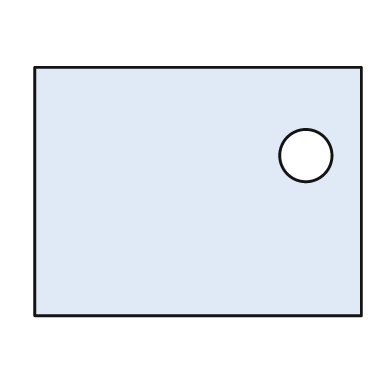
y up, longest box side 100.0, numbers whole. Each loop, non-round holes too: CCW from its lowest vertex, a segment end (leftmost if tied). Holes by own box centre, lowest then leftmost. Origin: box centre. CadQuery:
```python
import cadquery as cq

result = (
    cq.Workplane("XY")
    .moveTo(-50.0, -38.0)
    .lineTo(50.0, -38.0)
    .lineTo(50.0, 38.0)
    .lineTo(-50.0, 38.0)
    .close()
    .moveTo(33.0, 11.0)
    .circle(8.0)
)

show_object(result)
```